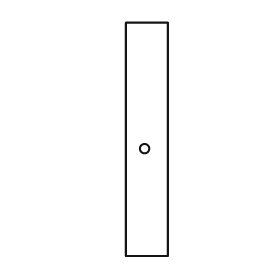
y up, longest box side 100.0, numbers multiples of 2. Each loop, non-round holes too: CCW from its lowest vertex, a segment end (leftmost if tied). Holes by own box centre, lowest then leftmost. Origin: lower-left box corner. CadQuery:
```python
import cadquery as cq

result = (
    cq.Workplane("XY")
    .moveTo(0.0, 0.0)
    .lineTo(18.0, 0.0)
    .lineTo(18.0, 100.0)
    .lineTo(0.0, 100.0)
    .close()
    .moveTo(8.0, 46.0)
    .circle(2.0)
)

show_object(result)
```